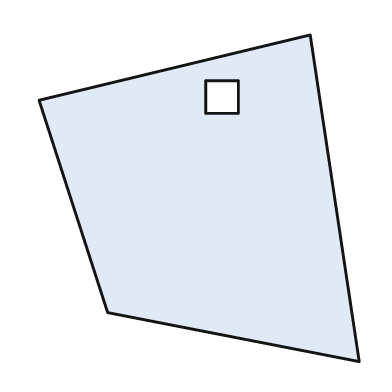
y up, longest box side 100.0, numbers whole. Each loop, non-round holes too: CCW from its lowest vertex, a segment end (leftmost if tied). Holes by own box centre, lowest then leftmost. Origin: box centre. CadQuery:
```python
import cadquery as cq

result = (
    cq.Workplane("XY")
    .moveTo(49.0, -50.0)
    .lineTo(34.0, 50.0)
    .lineTo(-49.0, 30.0)
    .lineTo(-28.0, -35.0)
    .close()
    .moveTo(2.0, 26.0)
    .lineTo(12.0, 26.0)
    .lineTo(12.0, 36.0)
    .lineTo(2.0, 36.0)
    .close()
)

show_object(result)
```